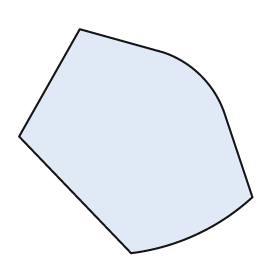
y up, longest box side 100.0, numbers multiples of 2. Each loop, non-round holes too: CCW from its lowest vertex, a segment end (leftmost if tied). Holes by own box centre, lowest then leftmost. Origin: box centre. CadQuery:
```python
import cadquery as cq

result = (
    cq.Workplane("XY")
    .moveTo(-2.0, -48.0)
    .threePointArc((26.0, -40.0), (50.0, -24.0))
    .lineTo(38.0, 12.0)
    .threePointArc((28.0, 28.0), (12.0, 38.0))
    .lineTo(-24.0, 48.0)
    .lineTo(-50.0, 2.0)
    .close()
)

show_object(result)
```